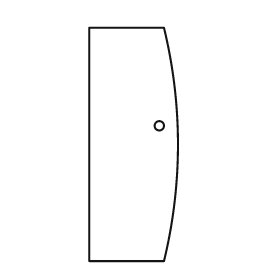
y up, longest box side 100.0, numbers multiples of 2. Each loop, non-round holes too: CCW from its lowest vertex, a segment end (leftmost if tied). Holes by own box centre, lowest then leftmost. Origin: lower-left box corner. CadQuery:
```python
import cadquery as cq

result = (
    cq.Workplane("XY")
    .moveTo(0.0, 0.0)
    .lineTo(32.0, 0.0)
    .threePointArc((38.0, 50.0), (32.0, 100.0))
    .lineTo(0.0, 100.0)
    .close()
    .moveTo(30.0, 58.0)
    .circle(2.0)
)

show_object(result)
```